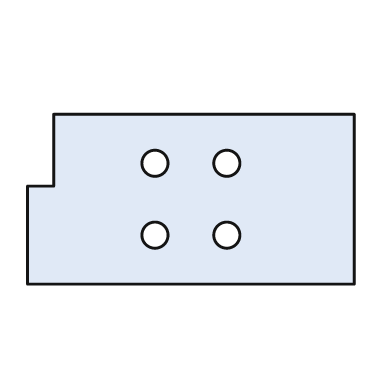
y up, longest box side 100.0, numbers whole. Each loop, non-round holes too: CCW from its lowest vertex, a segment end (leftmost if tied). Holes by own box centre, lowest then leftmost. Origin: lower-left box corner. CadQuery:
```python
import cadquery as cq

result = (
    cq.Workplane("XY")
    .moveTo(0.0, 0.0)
    .lineTo(100.0, 0.0)
    .lineTo(100.0, 52.0)
    .lineTo(8.0, 52.0)
    .lineTo(8.0, 30.0)
    .lineTo(0.0, 30.0)
    .close()
    .moveTo(39.0, 15.0)
    .circle(4.0)
    .moveTo(61.0, 15.0)
    .circle(4.0)
    .moveTo(39.0, 37.0)
    .circle(4.0)
    .moveTo(61.0, 37.0)
    .circle(4.0)
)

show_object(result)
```